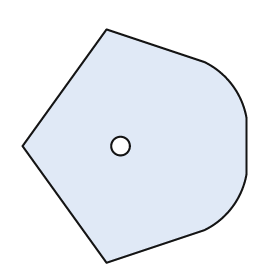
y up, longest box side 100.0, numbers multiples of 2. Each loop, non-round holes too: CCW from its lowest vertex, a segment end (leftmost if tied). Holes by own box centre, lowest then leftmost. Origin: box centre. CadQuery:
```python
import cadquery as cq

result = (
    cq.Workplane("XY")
    .moveTo(-12.0, -50.0)
    .lineTo(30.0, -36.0)
    .threePointArc((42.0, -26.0), (48.0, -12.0))
    .lineTo(48.0, 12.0)
    .threePointArc((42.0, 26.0), (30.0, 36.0))
    .lineTo(-12.0, 50.0)
    .lineTo(-48.0, 0.0)
    .close()
    .moveTo(-6.0, 0.0)
    .circle(4.0)
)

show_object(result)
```